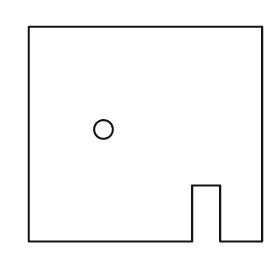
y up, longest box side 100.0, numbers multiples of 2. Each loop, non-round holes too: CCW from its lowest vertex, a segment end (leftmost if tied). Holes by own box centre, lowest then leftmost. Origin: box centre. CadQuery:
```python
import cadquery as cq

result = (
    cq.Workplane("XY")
    .moveTo(-50.0, -46.0)
    .lineTo(20.0, -46.0)
    .lineTo(20.0, -22.0)
    .lineTo(32.0, -22.0)
    .lineTo(32.0, -46.0)
    .lineTo(50.0, -46.0)
    .lineTo(50.0, 46.0)
    .lineTo(-50.0, 46.0)
    .close()
    .moveTo(-18.0, 2.0)
    .circle(4.0)
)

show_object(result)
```